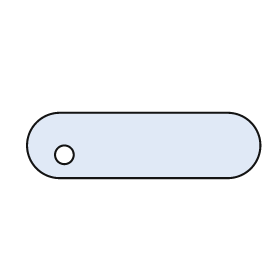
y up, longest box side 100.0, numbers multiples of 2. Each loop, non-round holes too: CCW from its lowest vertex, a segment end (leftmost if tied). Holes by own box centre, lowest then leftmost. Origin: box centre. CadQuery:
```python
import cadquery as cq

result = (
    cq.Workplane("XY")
    .moveTo(-36.0, -14.0)
    .lineTo(36.0, -14.0)
    .threePointArc((50.0, 0.0), (36.0, 14.0))
    .lineTo(-36.0, 14.0)
    .threePointArc((-50.0, 0.0), (-36.0, -14.0))
    .close()
    .moveTo(-34.0, -4.0)
    .circle(4.0)
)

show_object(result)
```